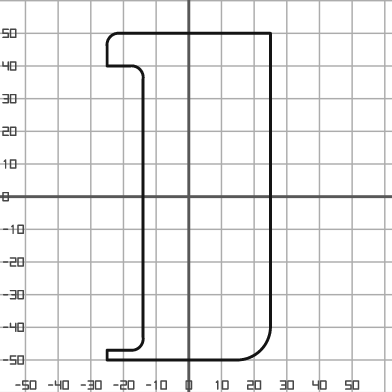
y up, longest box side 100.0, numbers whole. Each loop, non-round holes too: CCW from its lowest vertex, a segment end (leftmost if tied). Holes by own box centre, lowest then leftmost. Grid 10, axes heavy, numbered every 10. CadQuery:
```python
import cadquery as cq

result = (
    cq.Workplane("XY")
    .moveTo(-25.0, -50.0)
    .lineTo(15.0, -50.0)
    .threePointArc((22.0, -47.0), (25.0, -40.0))
    .lineTo(25.0, 50.0)
    .lineTo(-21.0, 50.0)
    .threePointArc((-24.0, 49.0), (-25.0, 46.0))
    .lineTo(-25.0, 40.0)
    .lineTo(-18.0, 40.0)
    .threePointArc((-15.0, 39.0), (-14.0, 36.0))
    .lineTo(-14.0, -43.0)
    .threePointArc((-15.0, -46.0), (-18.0, -47.0))
    .lineTo(-25.0, -47.0)
    .close()
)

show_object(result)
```